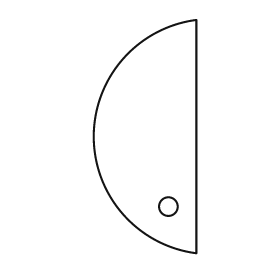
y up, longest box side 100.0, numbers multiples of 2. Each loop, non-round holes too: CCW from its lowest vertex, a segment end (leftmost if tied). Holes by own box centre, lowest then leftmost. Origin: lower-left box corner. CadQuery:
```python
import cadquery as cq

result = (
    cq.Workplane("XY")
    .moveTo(44.0, 0.0)
    .lineTo(44.0, 100.0)
    .threePointArc((0.0, 50.0), (44.0, 0.0))
    .close()
    .moveTo(32.0, 20.0)
    .circle(4.0)
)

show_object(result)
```